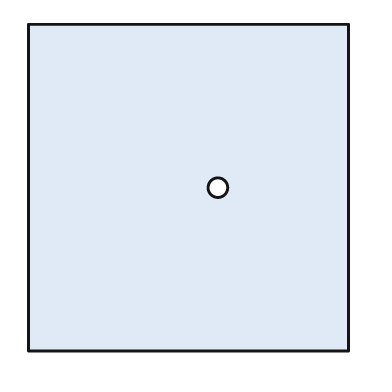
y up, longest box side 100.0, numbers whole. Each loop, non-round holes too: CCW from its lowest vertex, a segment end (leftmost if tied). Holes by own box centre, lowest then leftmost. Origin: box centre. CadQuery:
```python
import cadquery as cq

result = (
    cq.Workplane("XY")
    .moveTo(-49.0, -50.0)
    .lineTo(49.0, -50.0)
    .lineTo(49.0, 50.0)
    .lineTo(-49.0, 50.0)
    .close()
    .moveTo(9.0, 0.0)
    .circle(3.0)
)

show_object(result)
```